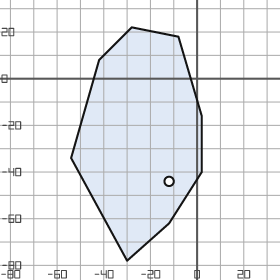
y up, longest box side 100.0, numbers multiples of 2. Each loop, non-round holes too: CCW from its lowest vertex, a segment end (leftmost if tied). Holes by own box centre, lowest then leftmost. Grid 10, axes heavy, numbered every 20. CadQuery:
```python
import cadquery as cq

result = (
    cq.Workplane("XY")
    .moveTo(-30.0, -78.0)
    .lineTo(-12.0, -62.0)
    .lineTo(2.0, -40.0)
    .lineTo(2.0, -16.0)
    .lineTo(-8.0, 18.0)
    .lineTo(-28.0, 22.0)
    .lineTo(-42.0, 8.0)
    .lineTo(-54.0, -34.0)
    .close()
    .moveTo(-12.0, -44.0)
    .circle(2.0)
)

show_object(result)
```